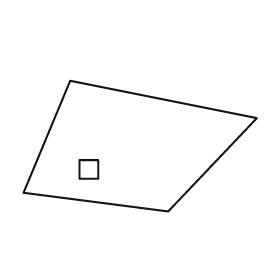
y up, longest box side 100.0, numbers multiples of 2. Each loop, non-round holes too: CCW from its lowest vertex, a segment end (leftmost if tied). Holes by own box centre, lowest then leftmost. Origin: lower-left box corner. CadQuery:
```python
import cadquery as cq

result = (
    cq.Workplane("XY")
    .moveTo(62.0, 0.0)
    .lineTo(100.0, 40.0)
    .lineTo(20.0, 56.0)
    .lineTo(0.0, 8.0)
    .close()
    .moveTo(24.0, 14.0)
    .lineTo(32.0, 14.0)
    .lineTo(32.0, 22.0)
    .lineTo(24.0, 22.0)
    .close()
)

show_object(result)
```